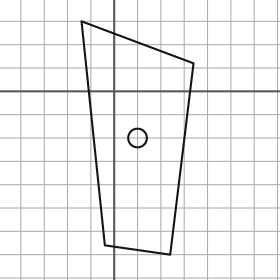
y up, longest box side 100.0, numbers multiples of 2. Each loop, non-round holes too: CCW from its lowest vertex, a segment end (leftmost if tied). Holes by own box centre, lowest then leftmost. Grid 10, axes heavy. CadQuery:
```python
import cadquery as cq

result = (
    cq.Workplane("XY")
    .moveTo(24.0, -70.0)
    .lineTo(34.0, 12.0)
    .lineTo(-14.0, 30.0)
    .lineTo(-4.0, -66.0)
    .close()
    .moveTo(10.0, -20.0)
    .circle(4.0)
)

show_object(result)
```